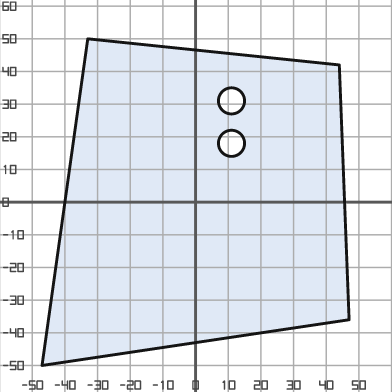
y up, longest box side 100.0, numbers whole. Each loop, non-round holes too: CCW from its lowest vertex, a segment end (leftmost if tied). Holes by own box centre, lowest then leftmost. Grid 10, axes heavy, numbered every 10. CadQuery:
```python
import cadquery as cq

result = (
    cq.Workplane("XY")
    .moveTo(-47.0, -50.0)
    .lineTo(47.0, -36.0)
    .lineTo(44.0, 42.0)
    .lineTo(-33.0, 50.0)
    .close()
    .moveTo(11.0, 18.0)
    .circle(4.0)
    .moveTo(11.0, 31.0)
    .circle(4.0)
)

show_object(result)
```